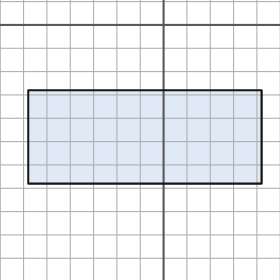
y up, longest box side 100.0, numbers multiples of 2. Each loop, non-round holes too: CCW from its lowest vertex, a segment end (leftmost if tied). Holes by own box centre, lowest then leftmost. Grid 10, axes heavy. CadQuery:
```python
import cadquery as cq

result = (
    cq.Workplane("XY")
    .moveTo(-58.0, -68.0)
    .lineTo(42.0, -68.0)
    .lineTo(42.0, -28.0)
    .lineTo(-58.0, -28.0)
    .close()
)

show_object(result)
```